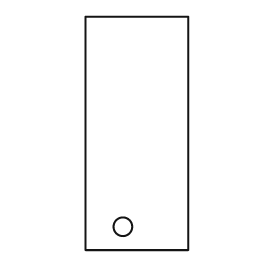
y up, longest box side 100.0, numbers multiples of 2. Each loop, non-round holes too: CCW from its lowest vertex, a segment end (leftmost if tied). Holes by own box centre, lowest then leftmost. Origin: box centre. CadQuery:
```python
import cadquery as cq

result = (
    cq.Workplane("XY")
    .moveTo(-22.0, -50.0)
    .lineTo(22.0, -50.0)
    .lineTo(22.0, 50.0)
    .lineTo(-22.0, 50.0)
    .close()
    .moveTo(-6.0, -40.0)
    .circle(4.0)
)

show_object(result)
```